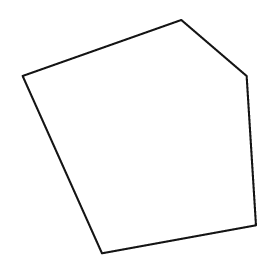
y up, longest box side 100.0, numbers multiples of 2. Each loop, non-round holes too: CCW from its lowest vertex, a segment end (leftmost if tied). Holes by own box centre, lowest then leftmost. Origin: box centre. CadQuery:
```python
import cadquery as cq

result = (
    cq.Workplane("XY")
    .moveTo(-16.0, -50.0)
    .lineTo(50.0, -38.0)
    .lineTo(46.0, 26.0)
    .lineTo(18.0, 50.0)
    .lineTo(-50.0, 26.0)
    .close()
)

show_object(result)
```